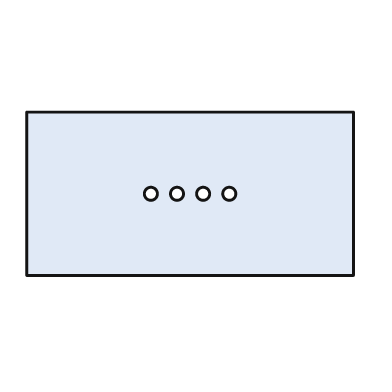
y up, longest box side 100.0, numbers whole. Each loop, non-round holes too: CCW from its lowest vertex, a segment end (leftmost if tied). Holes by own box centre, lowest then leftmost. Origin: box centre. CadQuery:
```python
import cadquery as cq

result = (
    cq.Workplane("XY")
    .moveTo(-50.0, -25.0)
    .lineTo(50.0, -25.0)
    .lineTo(50.0, 25.0)
    .lineTo(-50.0, 25.0)
    .close()
    .moveTo(-12.0, 0.0)
    .circle(2.0)
    .moveTo(-4.0, 0.0)
    .circle(2.0)
    .moveTo(4.0, 0.0)
    .circle(2.0)
    .moveTo(12.0, 0.0)
    .circle(2.0)
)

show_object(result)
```